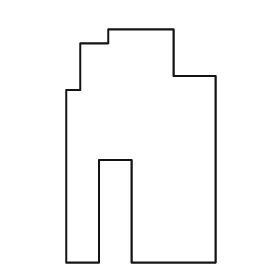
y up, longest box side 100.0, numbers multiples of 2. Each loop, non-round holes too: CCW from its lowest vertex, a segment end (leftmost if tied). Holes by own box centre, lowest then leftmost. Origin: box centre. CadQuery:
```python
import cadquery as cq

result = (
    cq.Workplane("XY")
    .moveTo(-32.0, -50.0)
    .lineTo(-18.0, -50.0)
    .lineTo(-18.0, -6.0)
    .lineTo(-4.0, -6.0)
    .lineTo(-4.0, -50.0)
    .lineTo(32.0, -50.0)
    .lineTo(32.0, 30.0)
    .lineTo(14.0, 30.0)
    .lineTo(14.0, 50.0)
    .lineTo(-14.0, 50.0)
    .lineTo(-14.0, 44.0)
    .lineTo(-26.0, 44.0)
    .lineTo(-26.0, 24.0)
    .lineTo(-32.0, 24.0)
    .close()
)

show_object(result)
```